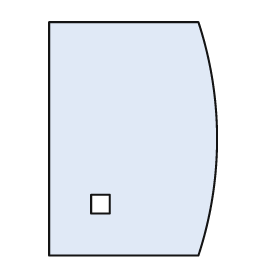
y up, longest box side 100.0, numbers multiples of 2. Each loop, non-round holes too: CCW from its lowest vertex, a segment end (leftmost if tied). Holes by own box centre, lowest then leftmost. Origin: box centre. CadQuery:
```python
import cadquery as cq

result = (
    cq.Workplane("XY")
    .moveTo(-36.0, -50.0)
    .lineTo(28.0, -50.0)
    .threePointArc((36.0, 0.0), (28.0, 50.0))
    .lineTo(-36.0, 50.0)
    .close()
    .moveTo(-18.0, -32.0)
    .lineTo(-10.0, -32.0)
    .lineTo(-10.0, -24.0)
    .lineTo(-18.0, -24.0)
    .close()
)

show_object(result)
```